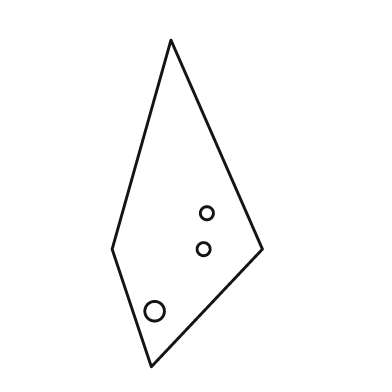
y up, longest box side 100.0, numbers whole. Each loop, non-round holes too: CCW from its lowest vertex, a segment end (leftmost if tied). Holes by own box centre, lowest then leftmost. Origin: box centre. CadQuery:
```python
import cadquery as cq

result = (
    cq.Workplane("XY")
    .moveTo(-11.0, -50.0)
    .lineTo(23.0, -14.0)
    .lineTo(-5.0, 50.0)
    .lineTo(-23.0, -14.0)
    .close()
    .moveTo(-10.0, -33.0)
    .circle(3.0)
    .moveTo(5.0, -14.0)
    .circle(2.0)
    .moveTo(6.0, -3.0)
    .circle(2.0)
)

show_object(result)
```